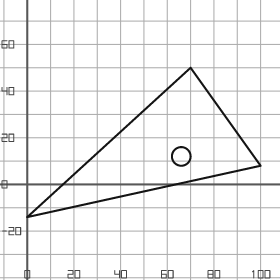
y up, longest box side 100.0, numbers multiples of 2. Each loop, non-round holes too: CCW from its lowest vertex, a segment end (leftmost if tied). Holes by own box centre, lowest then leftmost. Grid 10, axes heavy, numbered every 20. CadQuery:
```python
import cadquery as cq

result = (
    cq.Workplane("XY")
    .moveTo(0.0, -14.0)
    .lineTo(100.0, 8.0)
    .lineTo(70.0, 50.0)
    .close()
    .moveTo(66.0, 12.0)
    .circle(4.0)
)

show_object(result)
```